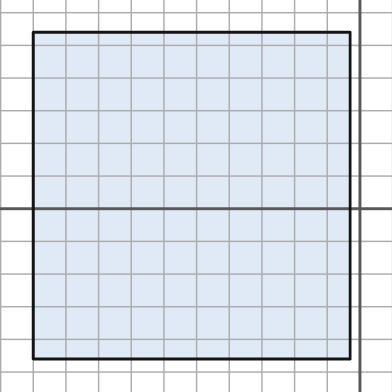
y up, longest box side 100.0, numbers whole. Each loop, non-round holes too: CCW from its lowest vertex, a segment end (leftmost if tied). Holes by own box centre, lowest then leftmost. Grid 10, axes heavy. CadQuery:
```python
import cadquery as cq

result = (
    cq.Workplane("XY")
    .moveTo(-100.0, -46.0)
    .lineTo(-3.0, -46.0)
    .lineTo(-3.0, 54.0)
    .lineTo(-100.0, 54.0)
    .close()
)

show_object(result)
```